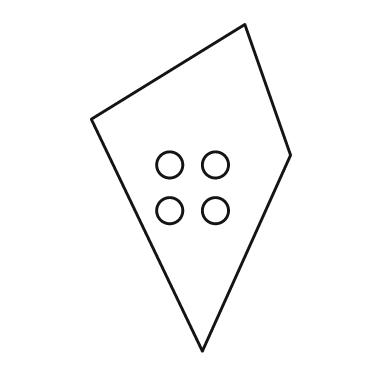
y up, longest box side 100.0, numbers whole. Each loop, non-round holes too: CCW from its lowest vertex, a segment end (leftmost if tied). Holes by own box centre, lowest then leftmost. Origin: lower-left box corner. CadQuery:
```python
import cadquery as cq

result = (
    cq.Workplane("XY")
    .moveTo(34.0, 0.0)
    .lineTo(61.0, 60.0)
    .lineTo(47.0, 100.0)
    .lineTo(0.0, 71.0)
    .close()
    .moveTo(24.0, 43.0)
    .circle(4.0)
    .moveTo(38.0, 43.0)
    .circle(4.0)
    .moveTo(24.0, 57.0)
    .circle(4.0)
    .moveTo(38.0, 57.0)
    .circle(4.0)
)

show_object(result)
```